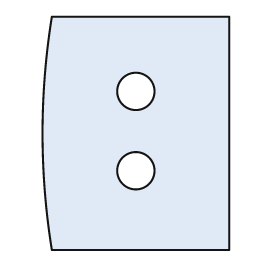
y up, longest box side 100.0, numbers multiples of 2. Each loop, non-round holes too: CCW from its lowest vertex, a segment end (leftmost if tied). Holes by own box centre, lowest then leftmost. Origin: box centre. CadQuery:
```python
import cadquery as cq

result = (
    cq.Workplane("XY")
    .moveTo(-36.0, -50.0)
    .lineTo(40.0, -50.0)
    .lineTo(40.0, 50.0)
    .lineTo(-36.0, 50.0)
    .threePointArc((-40.0, 0.0), (-36.0, -50.0))
    .close()
    .moveTo(0.0, -16.0)
    .circle(8.0)
    .moveTo(0.0, 18.0)
    .circle(8.0)
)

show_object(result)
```